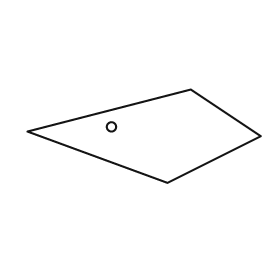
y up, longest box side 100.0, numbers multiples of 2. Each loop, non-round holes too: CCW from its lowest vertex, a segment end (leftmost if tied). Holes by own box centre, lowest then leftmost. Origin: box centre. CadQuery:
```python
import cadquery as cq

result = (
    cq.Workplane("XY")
    .moveTo(10.0, -20.0)
    .lineTo(50.0, 0.0)
    .lineTo(20.0, 20.0)
    .lineTo(-50.0, 2.0)
    .close()
    .moveTo(-14.0, 4.0)
    .circle(2.0)
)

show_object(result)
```